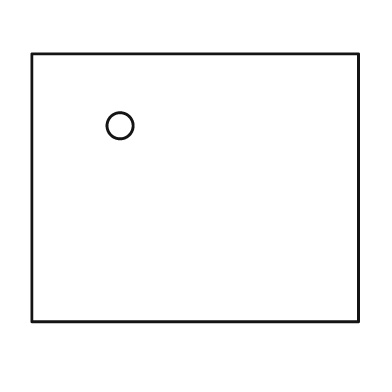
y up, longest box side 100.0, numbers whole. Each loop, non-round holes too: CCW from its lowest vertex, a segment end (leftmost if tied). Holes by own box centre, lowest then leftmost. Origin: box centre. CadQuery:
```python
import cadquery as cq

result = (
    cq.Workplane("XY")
    .moveTo(-50.0, -41.0)
    .lineTo(50.0, -41.0)
    .lineTo(50.0, 41.0)
    .lineTo(-50.0, 41.0)
    .close()
    .moveTo(-23.0, 19.0)
    .circle(4.0)
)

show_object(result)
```